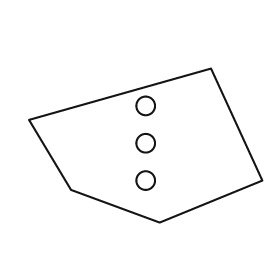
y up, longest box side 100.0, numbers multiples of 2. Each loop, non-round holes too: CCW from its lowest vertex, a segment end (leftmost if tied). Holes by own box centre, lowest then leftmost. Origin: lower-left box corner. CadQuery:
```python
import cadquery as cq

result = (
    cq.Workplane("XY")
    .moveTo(56.0, 0.0)
    .lineTo(100.0, 18.0)
    .lineTo(78.0, 66.0)
    .lineTo(0.0, 44.0)
    .lineTo(18.0, 14.0)
    .close()
    .moveTo(50.0, 18.0)
    .circle(4.0)
    .moveTo(50.0, 34.0)
    .circle(4.0)
    .moveTo(50.0, 50.0)
    .circle(4.0)
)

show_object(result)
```